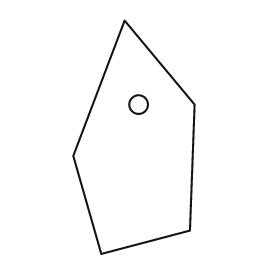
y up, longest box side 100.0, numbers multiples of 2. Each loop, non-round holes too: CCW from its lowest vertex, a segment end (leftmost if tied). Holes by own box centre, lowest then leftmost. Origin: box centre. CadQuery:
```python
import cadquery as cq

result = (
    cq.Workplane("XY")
    .moveTo(-14.0, -50.0)
    .lineTo(24.0, -40.0)
    .lineTo(26.0, 14.0)
    .lineTo(-4.0, 50.0)
    .lineTo(-26.0, -8.0)
    .close()
    .moveTo(2.0, 14.0)
    .circle(4.0)
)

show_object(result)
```